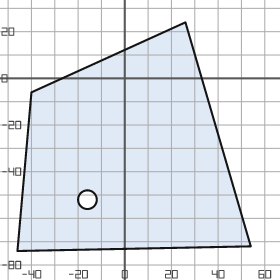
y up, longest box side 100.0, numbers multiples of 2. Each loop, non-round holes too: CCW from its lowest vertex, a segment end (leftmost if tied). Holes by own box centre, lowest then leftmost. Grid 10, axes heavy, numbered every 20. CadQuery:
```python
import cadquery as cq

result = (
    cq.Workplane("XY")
    .moveTo(-46.0, -74.0)
    .lineTo(54.0, -72.0)
    .lineTo(26.0, 24.0)
    .lineTo(-40.0, -6.0)
    .close()
    .moveTo(-16.0, -52.0)
    .circle(4.0)
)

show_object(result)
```